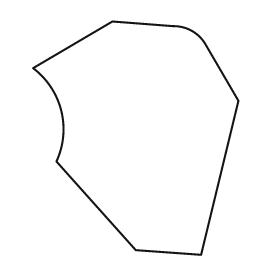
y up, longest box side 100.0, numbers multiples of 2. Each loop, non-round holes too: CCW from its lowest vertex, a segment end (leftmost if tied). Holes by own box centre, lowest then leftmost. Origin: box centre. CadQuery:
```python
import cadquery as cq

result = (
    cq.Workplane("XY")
    .moveTo(28.0, -50.0)
    .lineTo(44.0, 16.0)
    .lineTo(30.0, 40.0)
    .threePointArc((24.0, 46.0), (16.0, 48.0))
    .lineTo(-10.0, 50.0)
    .lineTo(-44.0, 30.0)
    .threePointArc((-32.0, 12.0), (-34.0, -10.0))
    .lineTo(0.0, -48.0)
    .close()
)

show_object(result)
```